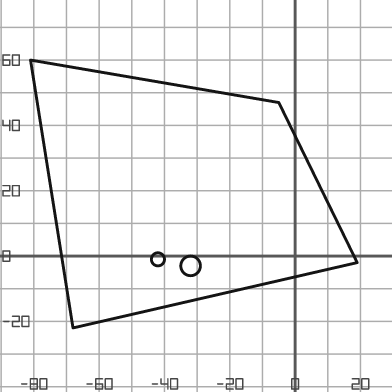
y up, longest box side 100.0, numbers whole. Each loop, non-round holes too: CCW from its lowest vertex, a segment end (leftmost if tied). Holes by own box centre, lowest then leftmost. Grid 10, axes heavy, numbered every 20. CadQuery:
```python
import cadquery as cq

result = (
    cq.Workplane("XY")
    .moveTo(-68.0, -22.0)
    .lineTo(19.0, -2.0)
    .lineTo(-5.0, 47.0)
    .lineTo(-81.0, 60.0)
    .close()
    .moveTo(-32.0, -3.0)
    .circle(3.0)
    .moveTo(-42.0, -1.0)
    .circle(2.0)
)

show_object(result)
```